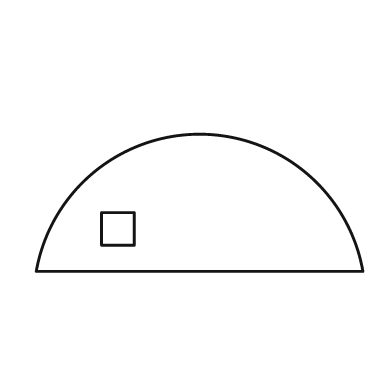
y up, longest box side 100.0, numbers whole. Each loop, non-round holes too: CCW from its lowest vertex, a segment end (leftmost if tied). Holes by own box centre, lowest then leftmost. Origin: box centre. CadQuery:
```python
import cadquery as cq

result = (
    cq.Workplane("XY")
    .moveTo(-50.0, -21.0)
    .lineTo(50.0, -21.0)
    .threePointArc((0.0, 21.0), (-50.0, -21.0))
    .close()
    .moveTo(-30.0, -13.0)
    .lineTo(-20.0, -13.0)
    .lineTo(-20.0, -3.0)
    .lineTo(-30.0, -3.0)
    .close()
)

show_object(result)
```